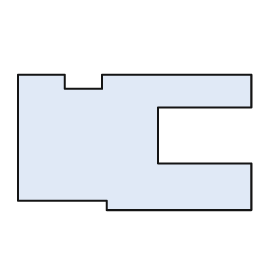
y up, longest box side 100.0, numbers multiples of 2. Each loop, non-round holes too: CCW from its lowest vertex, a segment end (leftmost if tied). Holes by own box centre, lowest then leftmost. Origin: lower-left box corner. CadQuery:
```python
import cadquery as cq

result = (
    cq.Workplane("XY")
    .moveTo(38.0, 0.0)
    .lineTo(100.0, 0.0)
    .lineTo(100.0, 20.0)
    .lineTo(60.0, 20.0)
    .lineTo(60.0, 44.0)
    .lineTo(100.0, 44.0)
    .lineTo(100.0, 58.0)
    .lineTo(36.0, 58.0)
    .lineTo(36.0, 52.0)
    .lineTo(20.0, 52.0)
    .lineTo(20.0, 58.0)
    .lineTo(0.0, 58.0)
    .lineTo(0.0, 4.0)
    .lineTo(38.0, 4.0)
    .close()
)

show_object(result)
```